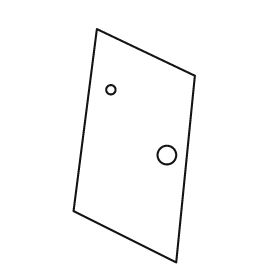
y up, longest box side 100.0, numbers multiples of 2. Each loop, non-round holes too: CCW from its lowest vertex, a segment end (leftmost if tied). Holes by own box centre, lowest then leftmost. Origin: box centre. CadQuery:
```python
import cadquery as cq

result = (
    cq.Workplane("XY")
    .moveTo(18.0, -50.0)
    .lineTo(26.0, 30.0)
    .lineTo(-16.0, 50.0)
    .lineTo(-26.0, -28.0)
    .close()
    .moveTo(14.0, -4.0)
    .circle(4.0)
    .moveTo(-10.0, 24.0)
    .circle(2.0)
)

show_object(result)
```